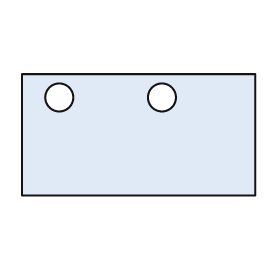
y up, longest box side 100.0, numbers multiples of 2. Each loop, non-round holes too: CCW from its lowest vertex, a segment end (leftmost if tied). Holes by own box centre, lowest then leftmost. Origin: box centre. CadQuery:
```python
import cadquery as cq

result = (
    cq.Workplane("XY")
    .moveTo(-50.0, -26.0)
    .lineTo(50.0, -26.0)
    .lineTo(50.0, 26.0)
    .lineTo(-50.0, 26.0)
    .close()
    .moveTo(-34.0, 16.0)
    .circle(6.0)
    .moveTo(10.0, 16.0)
    .circle(6.0)
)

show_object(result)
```